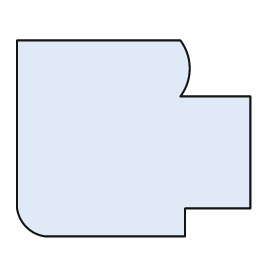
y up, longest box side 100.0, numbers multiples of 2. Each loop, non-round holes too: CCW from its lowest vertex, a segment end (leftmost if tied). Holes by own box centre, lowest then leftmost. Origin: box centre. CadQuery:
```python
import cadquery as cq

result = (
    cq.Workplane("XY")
    .moveTo(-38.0, -42.0)
    .lineTo(22.0, -42.0)
    .lineTo(22.0, -30.0)
    .lineTo(50.0, -30.0)
    .lineTo(50.0, 18.0)
    .lineTo(20.0, 18.0)
    .threePointArc((24.0, 30.0), (20.0, 42.0))
    .lineTo(-50.0, 42.0)
    .lineTo(-50.0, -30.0)
    .threePointArc((-46.0, -38.0), (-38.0, -42.0))
    .close()
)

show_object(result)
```